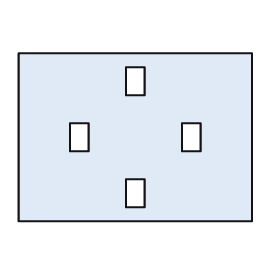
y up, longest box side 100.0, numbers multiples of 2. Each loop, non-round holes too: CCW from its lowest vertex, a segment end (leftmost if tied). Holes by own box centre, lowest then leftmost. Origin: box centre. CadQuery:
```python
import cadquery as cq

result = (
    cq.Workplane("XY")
    .moveTo(-50.0, -36.0)
    .lineTo(50.0, -36.0)
    .lineTo(50.0, 36.0)
    .lineTo(-50.0, 36.0)
    .close()
    .moveTo(-4.0, -30.0)
    .lineTo(4.0, -30.0)
    .lineTo(4.0, -18.0)
    .lineTo(-4.0, -18.0)
    .close()
    .moveTo(-28.0, -6.0)
    .lineTo(-20.0, -6.0)
    .lineTo(-20.0, 6.0)
    .lineTo(-28.0, 6.0)
    .close()
    .moveTo(20.0, -6.0)
    .lineTo(28.0, -6.0)
    .lineTo(28.0, 6.0)
    .lineTo(20.0, 6.0)
    .close()
    .moveTo(-4.0, 18.0)
    .lineTo(4.0, 18.0)
    .lineTo(4.0, 30.0)
    .lineTo(-4.0, 30.0)
    .close()
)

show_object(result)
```